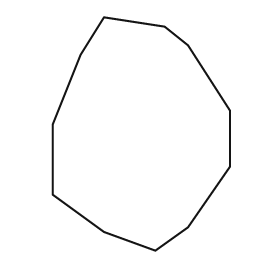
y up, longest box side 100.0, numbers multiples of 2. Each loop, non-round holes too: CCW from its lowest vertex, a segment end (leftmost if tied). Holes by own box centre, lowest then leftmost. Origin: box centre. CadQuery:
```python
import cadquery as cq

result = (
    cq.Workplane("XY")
    .moveTo(6.0, -50.0)
    .lineTo(20.0, -40.0)
    .lineTo(38.0, -14.0)
    .lineTo(38.0, 10.0)
    .lineTo(20.0, 38.0)
    .lineTo(10.0, 46.0)
    .lineTo(-16.0, 50.0)
    .lineTo(-26.0, 34.0)
    .lineTo(-38.0, 4.0)
    .lineTo(-38.0, -26.0)
    .lineTo(-16.0, -42.0)
    .close()
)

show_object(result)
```